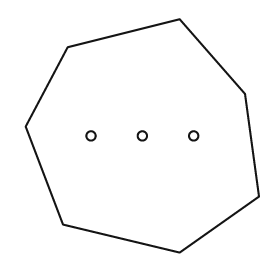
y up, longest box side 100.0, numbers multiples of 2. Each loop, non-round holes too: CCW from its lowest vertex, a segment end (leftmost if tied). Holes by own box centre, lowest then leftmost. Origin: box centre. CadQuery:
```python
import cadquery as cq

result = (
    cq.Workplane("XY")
    .moveTo(16.0, -50.0)
    .lineTo(50.0, -26.0)
    .lineTo(44.0, 18.0)
    .lineTo(16.0, 50.0)
    .lineTo(-32.0, 38.0)
    .lineTo(-50.0, 4.0)
    .lineTo(-34.0, -38.0)
    .close()
    .moveTo(-22.0, 0.0)
    .circle(2.0)
    .moveTo(0.0, 0.0)
    .circle(2.0)
    .moveTo(22.0, 0.0)
    .circle(2.0)
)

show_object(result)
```